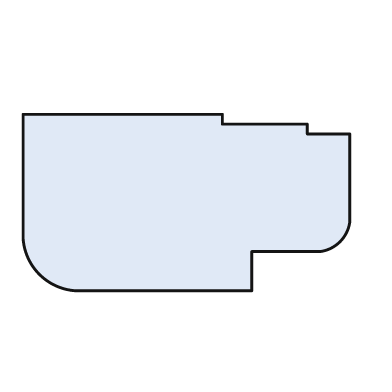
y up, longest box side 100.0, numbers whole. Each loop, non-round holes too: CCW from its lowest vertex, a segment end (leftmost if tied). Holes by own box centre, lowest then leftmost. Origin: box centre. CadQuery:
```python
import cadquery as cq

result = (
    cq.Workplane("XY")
    .moveTo(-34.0, -27.0)
    .lineTo(20.0, -27.0)
    .lineTo(20.0, -15.0)
    .lineTo(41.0, -15.0)
    .threePointArc((47.0, -12.0), (50.0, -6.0))
    .lineTo(50.0, 21.0)
    .lineTo(37.0, 21.0)
    .lineTo(37.0, 24.0)
    .lineTo(11.0, 24.0)
    .lineTo(11.0, 27.0)
    .lineTo(-50.0, 27.0)
    .lineTo(-50.0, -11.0)
    .threePointArc((-45.0, -22.0), (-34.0, -27.0))
    .close()
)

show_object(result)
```